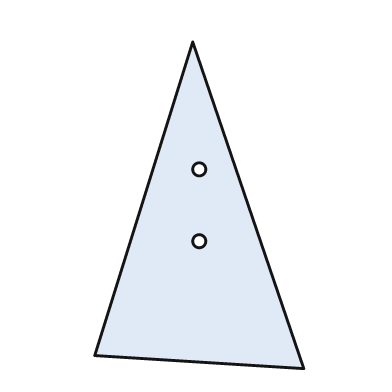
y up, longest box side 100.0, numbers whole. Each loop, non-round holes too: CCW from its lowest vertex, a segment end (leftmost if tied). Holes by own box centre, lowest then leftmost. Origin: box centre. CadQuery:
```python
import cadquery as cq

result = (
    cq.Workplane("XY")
    .moveTo(32.0, -50.0)
    .lineTo(-2.0, 50.0)
    .lineTo(-32.0, -46.0)
    .close()
    .moveTo(0.0, -11.0)
    .circle(2.0)
    .moveTo(0.0, 11.0)
    .circle(2.0)
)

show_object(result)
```